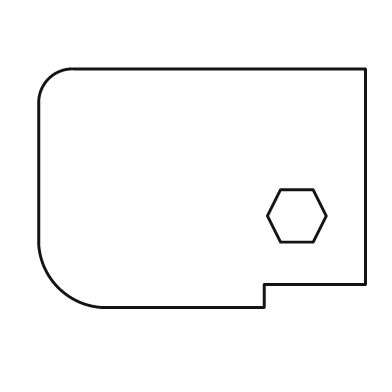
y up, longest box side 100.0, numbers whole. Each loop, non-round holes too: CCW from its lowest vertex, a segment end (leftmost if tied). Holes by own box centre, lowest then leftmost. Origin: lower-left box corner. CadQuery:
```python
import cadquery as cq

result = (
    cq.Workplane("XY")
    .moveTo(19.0, 0.0)
    .lineTo(69.0, 0.0)
    .lineTo(69.0, 7.0)
    .lineTo(100.0, 7.0)
    .lineTo(100.0, 73.0)
    .lineTo(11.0, 73.0)
    .threePointArc((3.0, 70.0), (0.0, 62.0))
    .lineTo(0.0, 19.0)
    .threePointArc((6.0, 6.0), (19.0, 0.0))
    .close()
    .moveTo(74.0, 20.0)
    .lineTo(84.0, 20.0)
    .lineTo(88.0, 28.0)
    .lineTo(84.0, 36.0)
    .lineTo(74.0, 36.0)
    .lineTo(70.0, 28.0)
    .close()
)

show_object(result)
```